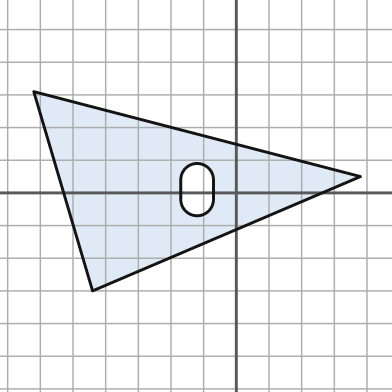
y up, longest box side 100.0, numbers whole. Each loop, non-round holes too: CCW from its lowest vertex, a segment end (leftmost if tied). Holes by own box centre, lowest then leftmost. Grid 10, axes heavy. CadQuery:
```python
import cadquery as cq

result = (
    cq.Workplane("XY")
    .moveTo(-44.0, -30.0)
    .lineTo(38.0, 5.0)
    .lineTo(-62.0, 31.0)
    .close()
    .moveTo(-17.0, -2.0)
    .threePointArc((-12.0, -7.0), (-7.0, -2.0))
    .lineTo(-7.0, 4.0)
    .threePointArc((-12.0, 9.0), (-17.0, 4.0))
    .close()
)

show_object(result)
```